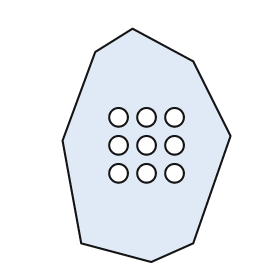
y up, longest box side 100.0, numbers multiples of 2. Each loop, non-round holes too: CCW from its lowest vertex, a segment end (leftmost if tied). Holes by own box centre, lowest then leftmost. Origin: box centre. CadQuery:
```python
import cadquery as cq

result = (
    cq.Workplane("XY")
    .moveTo(2.0, -50.0)
    .lineTo(20.0, -42.0)
    .lineTo(36.0, 4.0)
    .lineTo(20.0, 36.0)
    .lineTo(-6.0, 50.0)
    .lineTo(-22.0, 40.0)
    .lineTo(-36.0, 2.0)
    .lineTo(-28.0, -42.0)
    .close()
    .moveTo(-12.0, -12.0)
    .circle(4.0)
    .moveTo(0.0, -12.0)
    .circle(4.0)
    .moveTo(12.0, -12.0)
    .circle(4.0)
    .moveTo(-12.0, 0.0)
    .circle(4.0)
    .moveTo(0.0, 0.0)
    .circle(4.0)
    .moveTo(12.0, 0.0)
    .circle(4.0)
    .moveTo(-12.0, 12.0)
    .circle(4.0)
    .moveTo(0.0, 12.0)
    .circle(4.0)
    .moveTo(12.0, 12.0)
    .circle(4.0)
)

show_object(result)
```